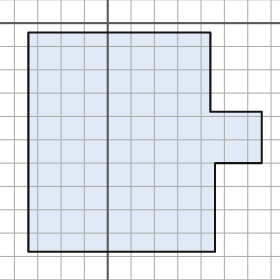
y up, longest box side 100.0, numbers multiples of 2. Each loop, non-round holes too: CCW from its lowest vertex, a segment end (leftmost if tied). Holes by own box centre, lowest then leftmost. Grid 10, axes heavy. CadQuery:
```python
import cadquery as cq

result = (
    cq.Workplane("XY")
    .moveTo(-34.0, -98.0)
    .lineTo(46.0, -98.0)
    .lineTo(46.0, -60.0)
    .lineTo(66.0, -60.0)
    .lineTo(66.0, -38.0)
    .lineTo(44.0, -38.0)
    .lineTo(44.0, -4.0)
    .lineTo(-34.0, -4.0)
    .close()
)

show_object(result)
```